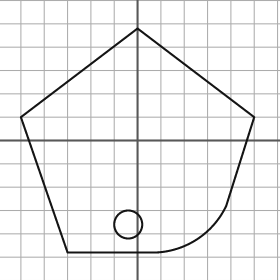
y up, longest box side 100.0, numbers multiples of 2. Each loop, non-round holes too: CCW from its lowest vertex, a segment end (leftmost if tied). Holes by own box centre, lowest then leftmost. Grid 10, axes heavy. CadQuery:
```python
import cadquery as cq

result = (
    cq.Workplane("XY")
    .moveTo(-30.0, -48.0)
    .lineTo(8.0, -48.0)
    .threePointArc((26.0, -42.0), (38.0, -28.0))
    .lineTo(50.0, 10.0)
    .lineTo(0.0, 48.0)
    .lineTo(-50.0, 10.0)
    .close()
    .moveTo(-4.0, -36.0)
    .circle(6.0)
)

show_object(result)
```